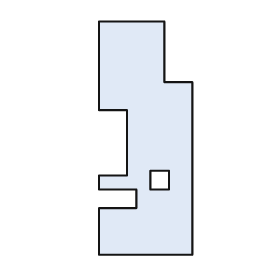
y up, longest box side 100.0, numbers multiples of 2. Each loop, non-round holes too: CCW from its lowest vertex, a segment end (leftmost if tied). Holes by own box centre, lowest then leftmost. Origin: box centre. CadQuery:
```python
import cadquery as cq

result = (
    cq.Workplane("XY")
    .moveTo(-20.0, -50.0)
    .lineTo(20.0, -50.0)
    .lineTo(20.0, 24.0)
    .lineTo(8.0, 24.0)
    .lineTo(8.0, 50.0)
    .lineTo(-20.0, 50.0)
    .lineTo(-20.0, 12.0)
    .lineTo(-8.0, 12.0)
    .lineTo(-8.0, -16.0)
    .lineTo(-20.0, -16.0)
    .lineTo(-20.0, -22.0)
    .lineTo(-4.0, -22.0)
    .lineTo(-4.0, -30.0)
    .lineTo(-20.0, -30.0)
    .close()
    .moveTo(2.0, -22.0)
    .lineTo(10.0, -22.0)
    .lineTo(10.0, -14.0)
    .lineTo(2.0, -14.0)
    .close()
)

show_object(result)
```